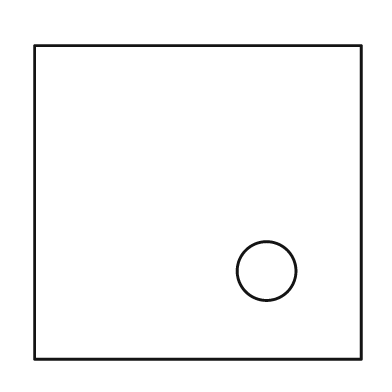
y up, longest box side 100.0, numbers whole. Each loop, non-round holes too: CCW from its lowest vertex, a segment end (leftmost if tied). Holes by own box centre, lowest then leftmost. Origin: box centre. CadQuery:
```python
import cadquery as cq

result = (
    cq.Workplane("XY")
    .moveTo(-50.0, -48.0)
    .lineTo(50.0, -48.0)
    .lineTo(50.0, 48.0)
    .lineTo(-50.0, 48.0)
    .close()
    .moveTo(21.0, -21.0)
    .circle(9.0)
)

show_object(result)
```